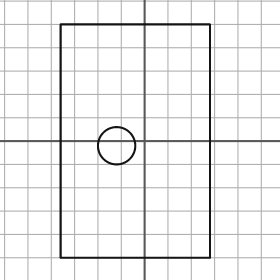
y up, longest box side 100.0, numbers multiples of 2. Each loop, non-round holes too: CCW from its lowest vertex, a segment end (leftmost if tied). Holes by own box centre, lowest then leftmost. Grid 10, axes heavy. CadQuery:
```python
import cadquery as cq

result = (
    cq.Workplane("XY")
    .moveTo(-36.0, -50.0)
    .lineTo(28.0, -50.0)
    .lineTo(28.0, 50.0)
    .lineTo(-36.0, 50.0)
    .close()
    .moveTo(-12.0, -2.0)
    .circle(8.0)
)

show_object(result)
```